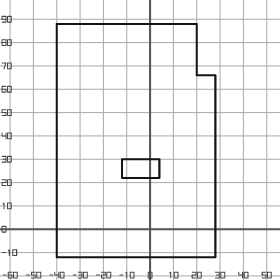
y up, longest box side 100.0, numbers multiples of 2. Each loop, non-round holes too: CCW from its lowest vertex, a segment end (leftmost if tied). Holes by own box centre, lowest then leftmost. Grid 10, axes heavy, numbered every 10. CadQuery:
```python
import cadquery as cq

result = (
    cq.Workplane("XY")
    .moveTo(-40.0, -12.0)
    .lineTo(28.0, -12.0)
    .lineTo(28.0, 66.0)
    .lineTo(20.0, 66.0)
    .lineTo(20.0, 88.0)
    .lineTo(-40.0, 88.0)
    .close()
    .moveTo(-12.0, 22.0)
    .lineTo(4.0, 22.0)
    .lineTo(4.0, 30.0)
    .lineTo(-12.0, 30.0)
    .close()
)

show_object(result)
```